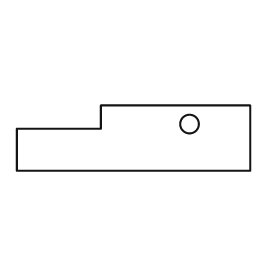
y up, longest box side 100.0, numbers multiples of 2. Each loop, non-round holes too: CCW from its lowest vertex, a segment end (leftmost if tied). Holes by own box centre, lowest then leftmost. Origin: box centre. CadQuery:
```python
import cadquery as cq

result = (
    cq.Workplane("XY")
    .moveTo(-50.0, -14.0)
    .lineTo(50.0, -14.0)
    .lineTo(50.0, 14.0)
    .lineTo(-14.0, 14.0)
    .lineTo(-14.0, 4.0)
    .lineTo(-50.0, 4.0)
    .close()
    .moveTo(24.0, 6.0)
    .circle(4.0)
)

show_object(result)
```